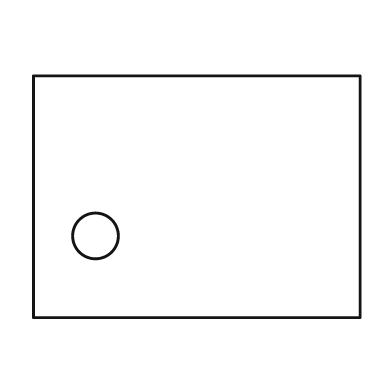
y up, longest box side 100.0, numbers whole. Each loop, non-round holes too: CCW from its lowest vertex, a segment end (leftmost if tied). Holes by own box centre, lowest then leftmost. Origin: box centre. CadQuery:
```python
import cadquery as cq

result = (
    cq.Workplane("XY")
    .moveTo(-50.0, -37.0)
    .lineTo(50.0, -37.0)
    .lineTo(50.0, 37.0)
    .lineTo(-50.0, 37.0)
    .close()
    .moveTo(-31.0, -12.0)
    .circle(7.0)
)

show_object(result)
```